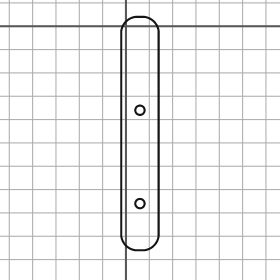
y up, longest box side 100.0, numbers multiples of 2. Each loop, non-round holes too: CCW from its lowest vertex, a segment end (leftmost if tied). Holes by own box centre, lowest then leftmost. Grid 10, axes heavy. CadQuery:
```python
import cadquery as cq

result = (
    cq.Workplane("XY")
    .moveTo(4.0, -96.0)
    .lineTo(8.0, -96.0)
    .threePointArc((12.0, -94.0), (14.0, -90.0))
    .lineTo(14.0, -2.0)
    .threePointArc((12.0, 2.0), (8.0, 4.0))
    .lineTo(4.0, 4.0)
    .threePointArc((0.0, 2.0), (-2.0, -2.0))
    .lineTo(-2.0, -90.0)
    .threePointArc((0.0, -94.0), (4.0, -96.0))
    .close()
    .moveTo(6.0, -76.0)
    .circle(2.0)
    .moveTo(6.0, -36.0)
    .circle(2.0)
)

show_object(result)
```